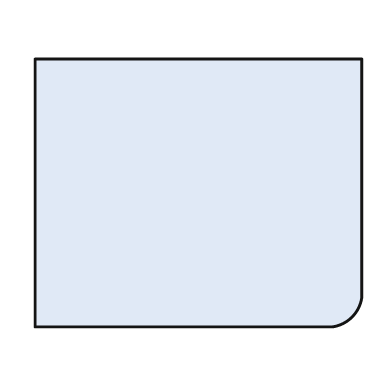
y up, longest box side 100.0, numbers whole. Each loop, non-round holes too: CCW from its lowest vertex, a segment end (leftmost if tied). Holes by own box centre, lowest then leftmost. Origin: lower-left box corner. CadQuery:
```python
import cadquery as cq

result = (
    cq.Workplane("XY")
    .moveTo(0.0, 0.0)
    .lineTo(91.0, 0.0)
    .threePointArc((97.0, 3.0), (100.0, 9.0))
    .lineTo(100.0, 82.0)
    .lineTo(0.0, 82.0)
    .close()
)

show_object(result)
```